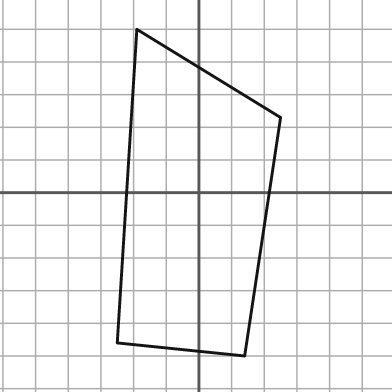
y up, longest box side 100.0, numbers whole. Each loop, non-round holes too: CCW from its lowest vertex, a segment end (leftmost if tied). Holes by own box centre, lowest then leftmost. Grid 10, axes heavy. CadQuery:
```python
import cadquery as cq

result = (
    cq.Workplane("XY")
    .moveTo(14.0, -50.0)
    .lineTo(25.0, 23.0)
    .lineTo(-19.0, 50.0)
    .lineTo(-25.0, -46.0)
    .close()
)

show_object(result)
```